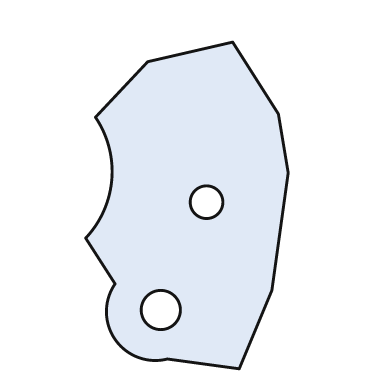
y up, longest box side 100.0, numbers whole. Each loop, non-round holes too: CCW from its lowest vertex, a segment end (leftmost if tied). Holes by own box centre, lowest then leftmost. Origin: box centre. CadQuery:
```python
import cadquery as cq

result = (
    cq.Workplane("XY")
    .moveTo(16.0, -50.0)
    .lineTo(26.0, -26.0)
    .lineTo(31.0, 10.0)
    .lineTo(28.0, 28.0)
    .lineTo(14.0, 50.0)
    .lineTo(-12.0, 44.0)
    .lineTo(-28.0, 27.0)
    .threePointArc((-23.0, 8.0), (-31.0, -10.0))
    .lineTo(-22.0, -24.0)
    .threePointArc((-22.0, -41.0), (-6.0, -47.0))
    .close()
    .moveTo(-8.0, -32.0)
    .circle(6.0)
    .moveTo(6.0, 1.0)
    .circle(5.0)
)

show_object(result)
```